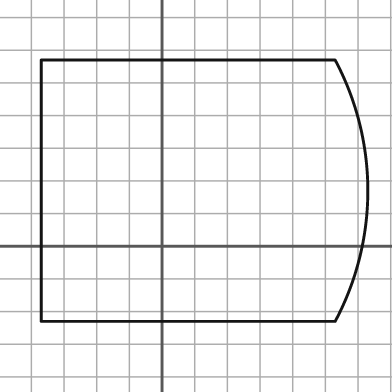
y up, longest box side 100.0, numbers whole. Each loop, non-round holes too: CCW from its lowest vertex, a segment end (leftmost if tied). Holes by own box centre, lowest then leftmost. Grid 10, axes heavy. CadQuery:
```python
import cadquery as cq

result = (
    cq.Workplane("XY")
    .moveTo(-37.0, -23.0)
    .lineTo(53.0, -23.0)
    .threePointArc((63.0, 17.0), (53.0, 57.0))
    .lineTo(-37.0, 57.0)
    .close()
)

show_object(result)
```